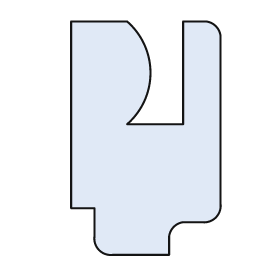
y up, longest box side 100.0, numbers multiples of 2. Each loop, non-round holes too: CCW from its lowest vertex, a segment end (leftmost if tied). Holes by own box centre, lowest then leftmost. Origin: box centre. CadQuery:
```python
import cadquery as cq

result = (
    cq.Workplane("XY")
    .moveTo(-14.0, -50.0)
    .lineTo(10.0, -50.0)
    .lineTo(10.0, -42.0)
    .threePointArc((12.0, -38.0), (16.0, -36.0))
    .lineTo(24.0, -36.0)
    .threePointArc((30.0, -34.0), (32.0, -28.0))
    .lineTo(32.0, 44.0)
    .threePointArc((30.0, 48.0), (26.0, 50.0))
    .lineTo(16.0, 50.0)
    .lineTo(16.0, 6.0)
    .lineTo(-8.0, 6.0)
    .threePointArc((2.0, 28.0), (-8.0, 50.0))
    .lineTo(-32.0, 50.0)
    .lineTo(-32.0, -30.0)
    .lineTo(-22.0, -30.0)
    .lineTo(-22.0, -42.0)
    .threePointArc((-20.0, -48.0), (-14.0, -50.0))
    .close()
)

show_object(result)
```